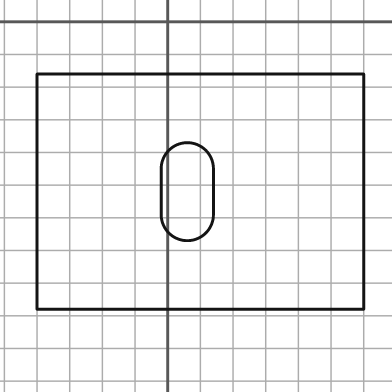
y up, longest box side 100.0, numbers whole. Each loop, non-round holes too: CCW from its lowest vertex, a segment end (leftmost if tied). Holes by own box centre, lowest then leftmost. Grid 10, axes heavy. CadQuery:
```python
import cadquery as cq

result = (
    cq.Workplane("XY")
    .moveTo(-40.0, -88.0)
    .lineTo(60.0, -88.0)
    .lineTo(60.0, -16.0)
    .lineTo(-40.0, -16.0)
    .close()
    .moveTo(-2.0, -59.0)
    .threePointArc((6.0, -67.0), (14.0, -59.0))
    .lineTo(14.0, -45.0)
    .threePointArc((6.0, -37.0), (-2.0, -45.0))
    .close()
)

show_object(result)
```